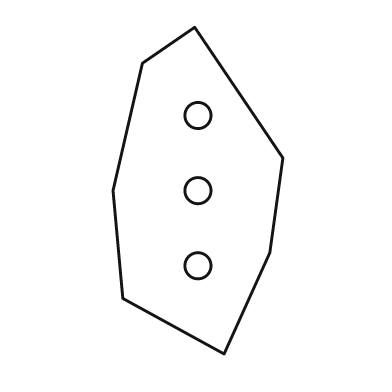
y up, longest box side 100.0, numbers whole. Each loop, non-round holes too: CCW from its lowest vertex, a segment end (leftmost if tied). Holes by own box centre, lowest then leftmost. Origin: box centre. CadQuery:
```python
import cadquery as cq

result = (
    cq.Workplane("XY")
    .moveTo(8.0, -50.0)
    .lineTo(22.0, -19.0)
    .lineTo(26.0, 10.0)
    .lineTo(-1.0, 50.0)
    .lineTo(-17.0, 39.0)
    .lineTo(-26.0, 0.0)
    .lineTo(-23.0, -33.0)
    .close()
    .moveTo(0.0, -23.0)
    .circle(4.0)
    .moveTo(0.0, 0.0)
    .circle(4.0)
    .moveTo(0.0, 23.0)
    .circle(4.0)
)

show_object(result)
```